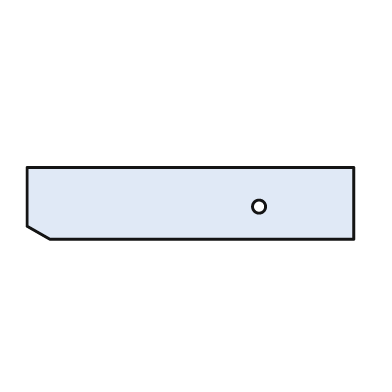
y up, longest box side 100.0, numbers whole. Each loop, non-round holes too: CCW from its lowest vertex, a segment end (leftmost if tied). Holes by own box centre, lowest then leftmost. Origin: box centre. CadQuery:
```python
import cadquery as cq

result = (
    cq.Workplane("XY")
    .moveTo(-43.0, -11.0)
    .lineTo(50.0, -11.0)
    .lineTo(50.0, 11.0)
    .lineTo(-50.0, 11.0)
    .lineTo(-50.0, -7.0)
    .close()
    .moveTo(21.0, -1.0)
    .circle(2.0)
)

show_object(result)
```